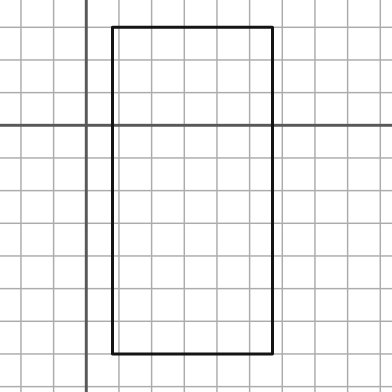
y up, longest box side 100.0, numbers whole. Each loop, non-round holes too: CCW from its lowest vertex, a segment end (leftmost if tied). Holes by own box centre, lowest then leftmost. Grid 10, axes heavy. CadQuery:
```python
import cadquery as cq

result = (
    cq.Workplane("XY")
    .moveTo(8.0, -70.0)
    .lineTo(57.0, -70.0)
    .lineTo(57.0, 30.0)
    .lineTo(8.0, 30.0)
    .close()
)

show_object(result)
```